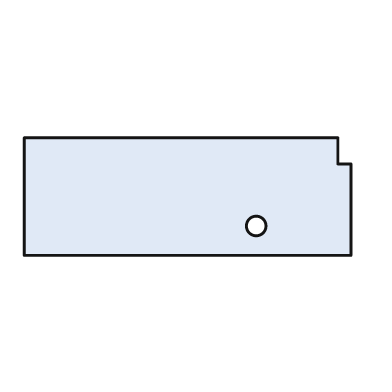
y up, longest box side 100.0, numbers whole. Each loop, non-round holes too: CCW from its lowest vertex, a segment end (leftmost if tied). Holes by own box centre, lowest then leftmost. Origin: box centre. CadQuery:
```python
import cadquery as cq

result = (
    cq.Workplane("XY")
    .moveTo(-50.0, -18.0)
    .lineTo(50.0, -18.0)
    .lineTo(50.0, 10.0)
    .lineTo(46.0, 10.0)
    .lineTo(46.0, 18.0)
    .lineTo(-50.0, 18.0)
    .close()
    .moveTo(21.0, -9.0)
    .circle(3.0)
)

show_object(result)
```